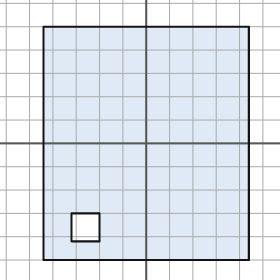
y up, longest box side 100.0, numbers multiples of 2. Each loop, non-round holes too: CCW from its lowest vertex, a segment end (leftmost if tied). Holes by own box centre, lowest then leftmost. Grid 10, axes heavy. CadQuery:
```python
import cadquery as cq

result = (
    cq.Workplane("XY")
    .moveTo(-44.0, -50.0)
    .lineTo(44.0, -50.0)
    .lineTo(44.0, 50.0)
    .lineTo(-44.0, 50.0)
    .close()
    .moveTo(-32.0, -42.0)
    .lineTo(-20.0, -42.0)
    .lineTo(-20.0, -30.0)
    .lineTo(-32.0, -30.0)
    .close()
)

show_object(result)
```